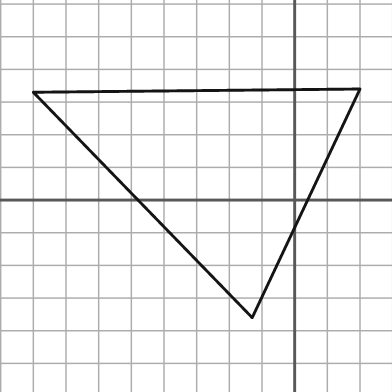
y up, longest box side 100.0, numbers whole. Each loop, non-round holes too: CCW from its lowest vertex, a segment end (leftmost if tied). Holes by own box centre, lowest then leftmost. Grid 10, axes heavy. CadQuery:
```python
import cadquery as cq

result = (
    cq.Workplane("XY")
    .moveTo(-13.0, -36.0)
    .lineTo(20.0, 34.0)
    .lineTo(-80.0, 33.0)
    .close()
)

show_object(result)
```